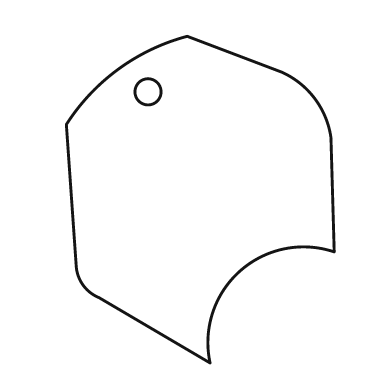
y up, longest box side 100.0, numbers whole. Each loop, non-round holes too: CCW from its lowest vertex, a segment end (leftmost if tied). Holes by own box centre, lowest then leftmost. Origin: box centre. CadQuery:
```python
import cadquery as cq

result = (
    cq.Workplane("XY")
    .moveTo(3.0, -50.0)
    .threePointArc((12.0, -22.0), (41.0, -16.0))
    .lineTo(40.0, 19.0)
    .threePointArc((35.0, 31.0), (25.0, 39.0))
    .lineTo(-4.0, 50.0)
    .threePointArc((-25.0, 40.0), (-41.0, 23.0))
    .lineTo(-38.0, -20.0)
    .threePointArc((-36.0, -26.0), (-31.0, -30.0))
    .close()
    .moveTo(-16.0, 33.0)
    .circle(4.0)
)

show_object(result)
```